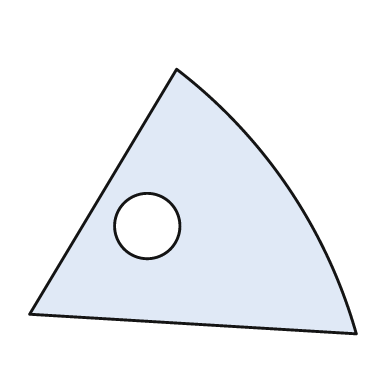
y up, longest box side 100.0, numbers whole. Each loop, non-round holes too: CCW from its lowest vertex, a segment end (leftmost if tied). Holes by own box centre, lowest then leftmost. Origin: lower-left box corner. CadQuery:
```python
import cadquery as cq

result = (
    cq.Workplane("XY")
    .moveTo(100.0, 0.0)
    .threePointArc((79.0, 45.0), (45.0, 81.0))
    .lineTo(0.0, 6.0)
    .close()
    .moveTo(36.0, 33.0)
    .circle(10.0)
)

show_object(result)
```